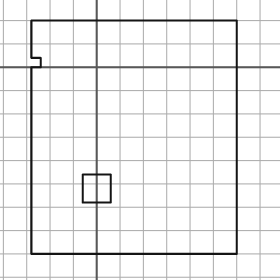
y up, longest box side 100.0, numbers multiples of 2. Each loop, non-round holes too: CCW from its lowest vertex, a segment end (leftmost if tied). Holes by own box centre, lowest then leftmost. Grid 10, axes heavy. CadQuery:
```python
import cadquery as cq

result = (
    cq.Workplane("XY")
    .moveTo(-28.0, -80.0)
    .lineTo(60.0, -80.0)
    .lineTo(60.0, 20.0)
    .lineTo(-28.0, 20.0)
    .lineTo(-28.0, 4.0)
    .lineTo(-24.0, 4.0)
    .lineTo(-24.0, 0.0)
    .lineTo(-28.0, 0.0)
    .close()
    .moveTo(-6.0, -58.0)
    .lineTo(6.0, -58.0)
    .lineTo(6.0, -46.0)
    .lineTo(-6.0, -46.0)
    .close()
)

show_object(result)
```